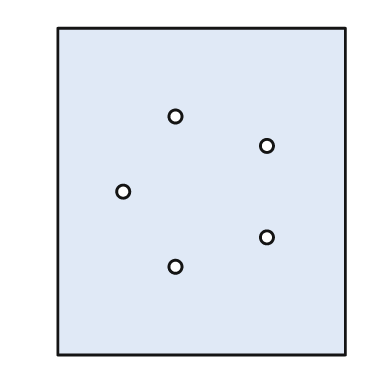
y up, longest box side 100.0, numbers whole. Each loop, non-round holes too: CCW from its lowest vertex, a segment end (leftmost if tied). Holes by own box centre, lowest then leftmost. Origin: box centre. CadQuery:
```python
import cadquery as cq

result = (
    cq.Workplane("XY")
    .moveTo(-44.0, -50.0)
    .lineTo(44.0, -50.0)
    .lineTo(44.0, 50.0)
    .lineTo(-44.0, 50.0)
    .close()
    .moveTo(-8.0, -23.0)
    .circle(2.0)
    .moveTo(20.0, -14.0)
    .circle(2.0)
    .moveTo(-24.0, 0.0)
    .circle(2.0)
    .moveTo(20.0, 14.0)
    .circle(2.0)
    .moveTo(-8.0, 23.0)
    .circle(2.0)
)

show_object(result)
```